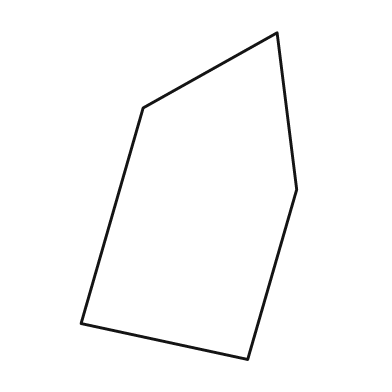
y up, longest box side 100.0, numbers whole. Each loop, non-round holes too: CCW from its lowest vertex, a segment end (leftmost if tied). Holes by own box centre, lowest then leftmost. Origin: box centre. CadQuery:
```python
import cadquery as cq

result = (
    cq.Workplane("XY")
    .moveTo(18.0, -50.0)
    .lineTo(33.0, 2.0)
    .lineTo(27.0, 50.0)
    .lineTo(-14.0, 27.0)
    .lineTo(-33.0, -39.0)
    .close()
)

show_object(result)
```